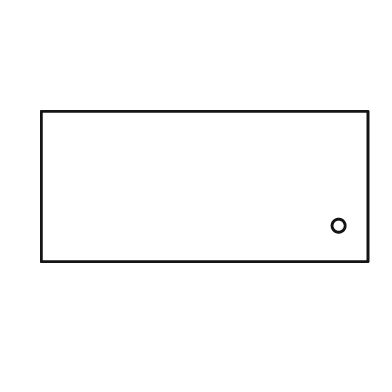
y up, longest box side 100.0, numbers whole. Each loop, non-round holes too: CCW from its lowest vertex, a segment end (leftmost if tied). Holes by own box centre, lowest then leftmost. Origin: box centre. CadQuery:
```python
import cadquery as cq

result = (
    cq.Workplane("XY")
    .moveTo(-50.0, -23.0)
    .lineTo(50.0, -23.0)
    .lineTo(50.0, 23.0)
    .lineTo(-50.0, 23.0)
    .close()
    .moveTo(41.0, -12.0)
    .circle(2.0)
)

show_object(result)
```